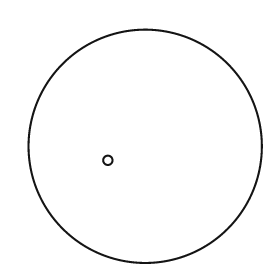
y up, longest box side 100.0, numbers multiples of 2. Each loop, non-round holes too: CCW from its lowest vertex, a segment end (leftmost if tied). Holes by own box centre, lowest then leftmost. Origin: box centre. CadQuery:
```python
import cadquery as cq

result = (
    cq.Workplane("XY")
    .moveTo(0.0, 0.0)
    .circle(50.0)
    .moveTo(-16.0, -6.0)
    .circle(2.0)
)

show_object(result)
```